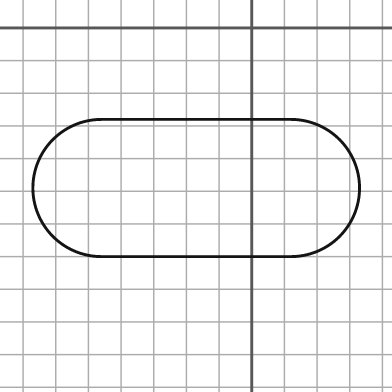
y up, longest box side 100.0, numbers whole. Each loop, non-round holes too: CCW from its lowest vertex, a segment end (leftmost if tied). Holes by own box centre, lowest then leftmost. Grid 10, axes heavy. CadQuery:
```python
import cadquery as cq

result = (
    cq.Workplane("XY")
    .moveTo(-46.0, -70.0)
    .lineTo(12.0, -70.0)
    .threePointArc((33.0, -49.0), (12.0, -28.0))
    .lineTo(-46.0, -28.0)
    .threePointArc((-67.0, -49.0), (-46.0, -70.0))
    .close()
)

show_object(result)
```